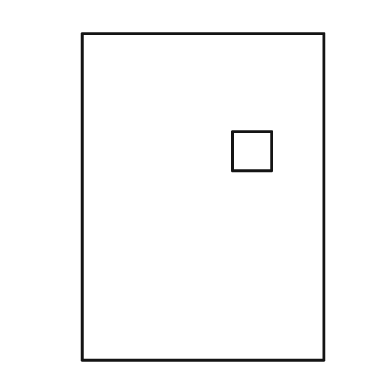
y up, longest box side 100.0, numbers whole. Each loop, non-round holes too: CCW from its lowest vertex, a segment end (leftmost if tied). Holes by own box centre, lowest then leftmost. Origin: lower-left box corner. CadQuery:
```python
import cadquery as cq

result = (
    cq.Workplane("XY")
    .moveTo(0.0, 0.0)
    .lineTo(74.0, 0.0)
    .lineTo(74.0, 100.0)
    .lineTo(0.0, 100.0)
    .close()
    .moveTo(46.0, 58.0)
    .lineTo(58.0, 58.0)
    .lineTo(58.0, 70.0)
    .lineTo(46.0, 70.0)
    .close()
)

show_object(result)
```